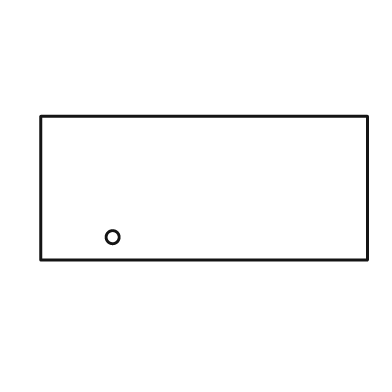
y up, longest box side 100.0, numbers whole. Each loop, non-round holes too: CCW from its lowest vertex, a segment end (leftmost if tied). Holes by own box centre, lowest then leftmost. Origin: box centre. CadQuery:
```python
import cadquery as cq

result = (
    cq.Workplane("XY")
    .moveTo(-50.0, -22.0)
    .lineTo(50.0, -22.0)
    .lineTo(50.0, 22.0)
    .lineTo(-50.0, 22.0)
    .close()
    .moveTo(-28.0, -15.0)
    .circle(2.0)
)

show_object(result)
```